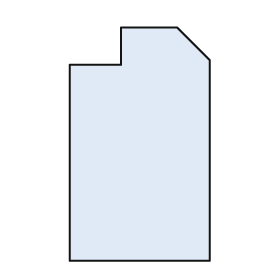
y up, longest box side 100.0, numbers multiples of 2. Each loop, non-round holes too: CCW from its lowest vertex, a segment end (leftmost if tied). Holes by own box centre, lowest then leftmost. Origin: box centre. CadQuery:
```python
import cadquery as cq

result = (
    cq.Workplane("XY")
    .moveTo(-30.0, -50.0)
    .lineTo(30.0, -50.0)
    .lineTo(30.0, 36.0)
    .lineTo(16.0, 50.0)
    .lineTo(-8.0, 50.0)
    .lineTo(-8.0, 34.0)
    .lineTo(-30.0, 34.0)
    .close()
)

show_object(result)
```